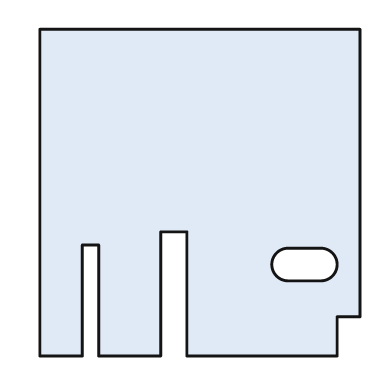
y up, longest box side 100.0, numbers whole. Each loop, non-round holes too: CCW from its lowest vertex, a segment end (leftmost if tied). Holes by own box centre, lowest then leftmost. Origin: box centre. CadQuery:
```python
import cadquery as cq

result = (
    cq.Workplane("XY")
    .moveTo(-49.0, -50.0)
    .lineTo(-36.0, -50.0)
    .lineTo(-36.0, -16.0)
    .lineTo(-31.0, -16.0)
    .lineTo(-31.0, -50.0)
    .lineTo(-12.0, -50.0)
    .lineTo(-12.0, -12.0)
    .lineTo(-4.0, -12.0)
    .lineTo(-4.0, -50.0)
    .lineTo(42.0, -50.0)
    .lineTo(42.0, -38.0)
    .lineTo(49.0, -38.0)
    .lineTo(49.0, 50.0)
    .lineTo(-49.0, 50.0)
    .close()
    .moveTo(27.0, -27.0)
    .lineTo(37.0, -27.0)
    .threePointArc((42.0, -22.0), (37.0, -17.0))
    .lineTo(27.0, -17.0)
    .threePointArc((22.0, -22.0), (27.0, -27.0))
    .close()
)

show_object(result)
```